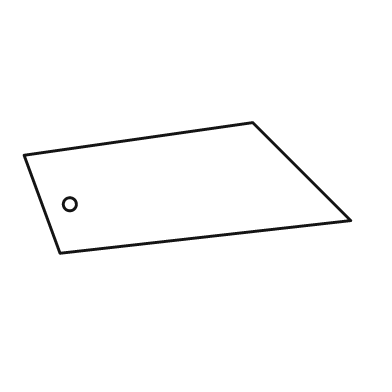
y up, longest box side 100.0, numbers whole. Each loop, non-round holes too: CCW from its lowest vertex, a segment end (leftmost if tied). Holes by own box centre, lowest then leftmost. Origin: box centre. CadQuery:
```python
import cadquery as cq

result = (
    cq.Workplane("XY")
    .moveTo(-39.0, -20.0)
    .lineTo(50.0, -10.0)
    .lineTo(20.0, 20.0)
    .lineTo(-50.0, 10.0)
    .close()
    .moveTo(-36.0, -5.0)
    .circle(2.0)
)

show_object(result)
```